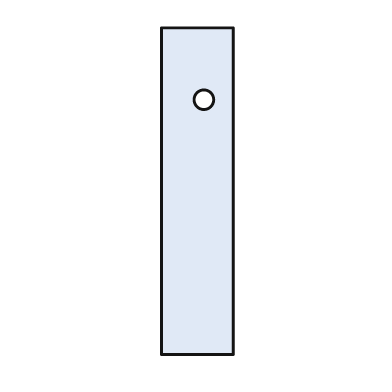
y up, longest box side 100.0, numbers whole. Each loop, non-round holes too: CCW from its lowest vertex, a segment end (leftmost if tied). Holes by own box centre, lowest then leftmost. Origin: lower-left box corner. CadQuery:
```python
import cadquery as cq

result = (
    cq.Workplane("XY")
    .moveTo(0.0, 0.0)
    .lineTo(22.0, 0.0)
    .lineTo(22.0, 100.0)
    .lineTo(0.0, 100.0)
    .close()
    .moveTo(13.0, 78.0)
    .circle(3.0)
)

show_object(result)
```